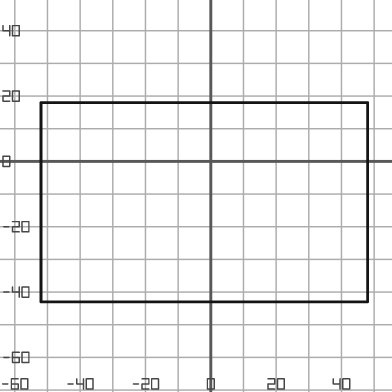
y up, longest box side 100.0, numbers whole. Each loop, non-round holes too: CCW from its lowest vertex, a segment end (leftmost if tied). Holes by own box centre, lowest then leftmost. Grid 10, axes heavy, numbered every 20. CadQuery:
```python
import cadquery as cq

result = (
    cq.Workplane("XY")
    .moveTo(-52.0, -43.0)
    .lineTo(48.0, -43.0)
    .lineTo(48.0, 18.0)
    .lineTo(-52.0, 18.0)
    .close()
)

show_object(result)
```